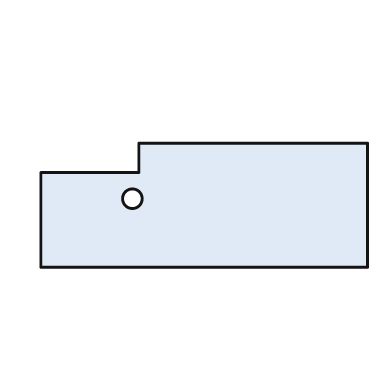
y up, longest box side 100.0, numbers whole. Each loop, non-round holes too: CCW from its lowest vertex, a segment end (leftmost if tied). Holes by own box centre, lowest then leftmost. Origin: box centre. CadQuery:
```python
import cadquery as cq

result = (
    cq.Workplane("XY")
    .moveTo(-50.0, -19.0)
    .lineTo(50.0, -19.0)
    .lineTo(50.0, 19.0)
    .lineTo(-20.0, 19.0)
    .lineTo(-20.0, 10.0)
    .lineTo(-50.0, 10.0)
    .close()
    .moveTo(-22.0, 2.0)
    .circle(3.0)
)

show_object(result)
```